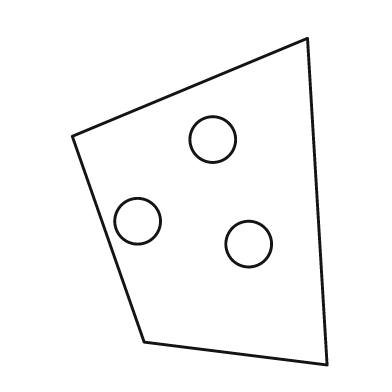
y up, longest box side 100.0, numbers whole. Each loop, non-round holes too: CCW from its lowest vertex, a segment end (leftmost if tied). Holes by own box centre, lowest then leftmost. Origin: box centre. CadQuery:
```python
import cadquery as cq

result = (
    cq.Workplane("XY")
    .moveTo(39.0, -50.0)
    .lineTo(33.0, 50.0)
    .lineTo(-39.0, 20.0)
    .lineTo(-17.0, -43.0)
    .close()
    .moveTo(15.0, -13.0)
    .circle(7.0)
    .moveTo(-19.0, -6.0)
    .circle(7.0)
    .moveTo(4.0, 19.0)
    .circle(7.0)
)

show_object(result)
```